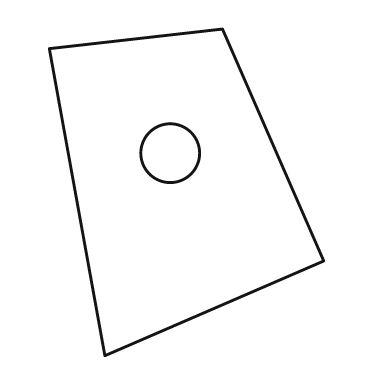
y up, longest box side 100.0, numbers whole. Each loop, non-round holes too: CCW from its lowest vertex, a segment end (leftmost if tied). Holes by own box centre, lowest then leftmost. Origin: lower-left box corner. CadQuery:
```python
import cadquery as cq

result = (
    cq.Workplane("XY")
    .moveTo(17.0, 0.0)
    .lineTo(84.0, 29.0)
    .lineTo(53.0, 100.0)
    .lineTo(0.0, 94.0)
    .close()
    .moveTo(37.0, 62.0)
    .circle(9.0)
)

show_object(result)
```